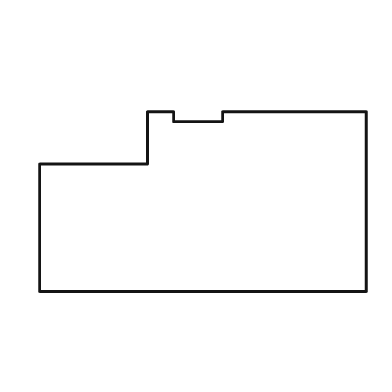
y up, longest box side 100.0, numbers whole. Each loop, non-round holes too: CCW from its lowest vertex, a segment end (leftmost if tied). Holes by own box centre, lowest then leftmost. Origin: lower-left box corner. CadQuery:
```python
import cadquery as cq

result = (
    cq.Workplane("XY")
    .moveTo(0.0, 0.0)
    .lineTo(100.0, 0.0)
    .lineTo(100.0, 55.0)
    .lineTo(56.0, 55.0)
    .lineTo(56.0, 52.0)
    .lineTo(41.0, 52.0)
    .lineTo(41.0, 55.0)
    .lineTo(33.0, 55.0)
    .lineTo(33.0, 39.0)
    .lineTo(0.0, 39.0)
    .close()
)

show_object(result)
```